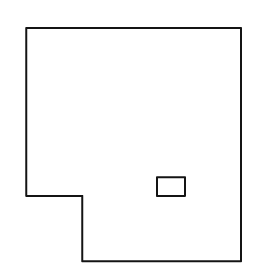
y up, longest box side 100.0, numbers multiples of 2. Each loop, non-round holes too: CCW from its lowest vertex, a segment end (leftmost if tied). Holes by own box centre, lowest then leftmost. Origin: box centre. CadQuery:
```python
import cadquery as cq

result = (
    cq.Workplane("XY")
    .moveTo(-22.0, -50.0)
    .lineTo(46.0, -50.0)
    .lineTo(46.0, 50.0)
    .lineTo(-46.0, 50.0)
    .lineTo(-46.0, -22.0)
    .lineTo(-22.0, -22.0)
    .close()
    .moveTo(10.0, -22.0)
    .lineTo(22.0, -22.0)
    .lineTo(22.0, -14.0)
    .lineTo(10.0, -14.0)
    .close()
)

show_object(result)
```